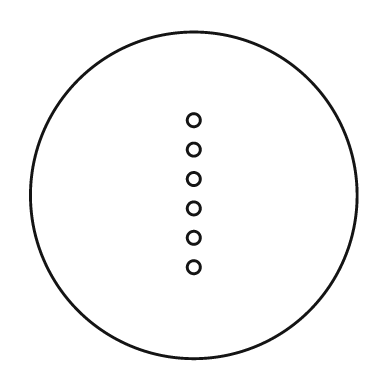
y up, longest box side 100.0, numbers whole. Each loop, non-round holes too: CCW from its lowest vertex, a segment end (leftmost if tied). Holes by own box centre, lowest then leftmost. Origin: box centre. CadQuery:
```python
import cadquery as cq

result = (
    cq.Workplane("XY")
    .moveTo(0.0, 0.0)
    .circle(50.0)
    .moveTo(0.0, -22.0)
    .circle(2.0)
    .moveTo(0.0, -13.0)
    .circle(2.0)
    .moveTo(0.0, -4.0)
    .circle(2.0)
    .moveTo(0.0, 5.0)
    .circle(2.0)
    .moveTo(0.0, 14.0)
    .circle(2.0)
    .moveTo(0.0, 23.0)
    .circle(2.0)
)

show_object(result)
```